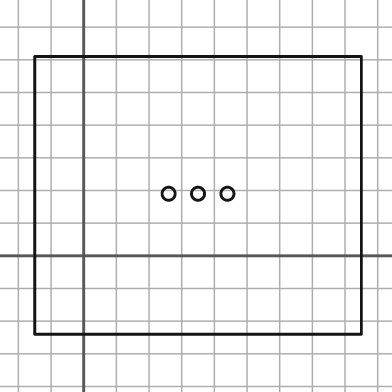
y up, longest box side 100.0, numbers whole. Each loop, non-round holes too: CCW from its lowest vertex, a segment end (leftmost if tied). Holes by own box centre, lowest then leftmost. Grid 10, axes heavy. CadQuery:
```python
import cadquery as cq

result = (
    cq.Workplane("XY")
    .moveTo(-15.0, -24.0)
    .lineTo(85.0, -24.0)
    .lineTo(85.0, 61.0)
    .lineTo(-15.0, 61.0)
    .close()
    .moveTo(26.0, 19.0)
    .circle(2.0)
    .moveTo(35.0, 19.0)
    .circle(2.0)
    .moveTo(44.0, 19.0)
    .circle(2.0)
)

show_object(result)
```